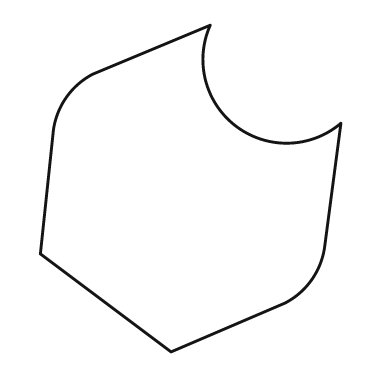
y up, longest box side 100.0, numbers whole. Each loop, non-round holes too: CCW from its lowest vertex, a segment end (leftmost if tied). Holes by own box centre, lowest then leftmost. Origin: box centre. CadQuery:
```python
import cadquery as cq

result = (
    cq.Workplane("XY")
    .moveTo(-6.0, -50.0)
    .lineTo(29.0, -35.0)
    .threePointArc((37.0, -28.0), (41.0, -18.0))
    .lineTo(46.0, 20.0)
    .threePointArc((14.0, 19.0), (6.0, 50.0))
    .lineTo(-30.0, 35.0)
    .threePointArc((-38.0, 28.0), (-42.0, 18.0))
    .lineTo(-46.0, -20.0)
    .close()
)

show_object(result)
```